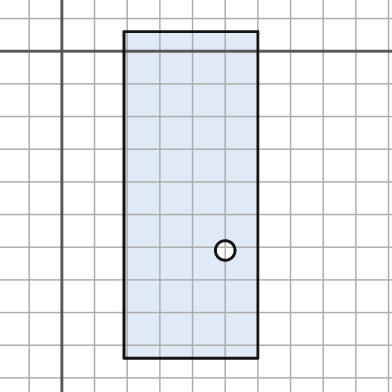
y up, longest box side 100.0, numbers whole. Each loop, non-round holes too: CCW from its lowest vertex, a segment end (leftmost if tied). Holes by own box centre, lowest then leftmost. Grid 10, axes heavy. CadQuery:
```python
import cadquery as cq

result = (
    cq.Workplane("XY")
    .moveTo(19.0, -94.0)
    .lineTo(60.0, -94.0)
    .lineTo(60.0, 6.0)
    .lineTo(19.0, 6.0)
    .close()
    .moveTo(50.0, -61.0)
    .circle(3.0)
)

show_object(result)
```